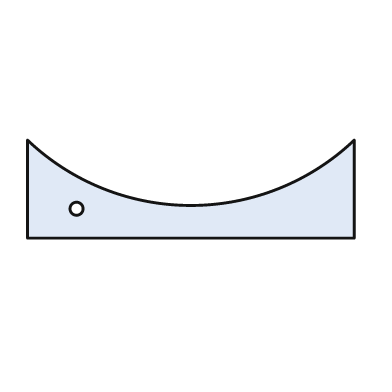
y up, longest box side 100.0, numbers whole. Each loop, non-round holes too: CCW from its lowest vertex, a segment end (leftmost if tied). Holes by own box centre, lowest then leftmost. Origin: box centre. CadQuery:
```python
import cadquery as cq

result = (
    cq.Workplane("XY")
    .moveTo(-50.0, -15.0)
    .lineTo(50.0, -15.0)
    .lineTo(50.0, 15.0)
    .threePointArc((0.0, -5.0), (-50.0, 15.0))
    .close()
    .moveTo(-35.0, -6.0)
    .circle(2.0)
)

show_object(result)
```